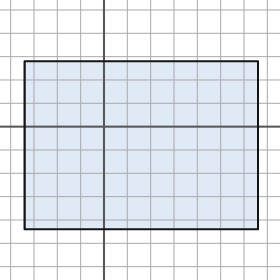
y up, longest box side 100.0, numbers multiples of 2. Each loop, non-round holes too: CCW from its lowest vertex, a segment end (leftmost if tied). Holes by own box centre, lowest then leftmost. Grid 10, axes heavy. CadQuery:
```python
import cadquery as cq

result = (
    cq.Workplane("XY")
    .moveTo(-34.0, -44.0)
    .lineTo(66.0, -44.0)
    .lineTo(66.0, 28.0)
    .lineTo(-34.0, 28.0)
    .close()
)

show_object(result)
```